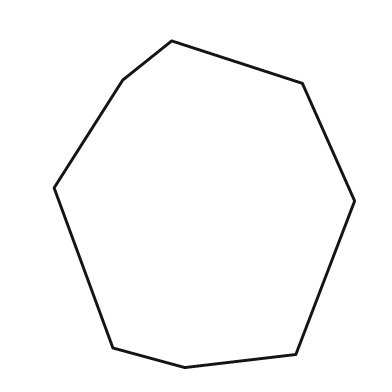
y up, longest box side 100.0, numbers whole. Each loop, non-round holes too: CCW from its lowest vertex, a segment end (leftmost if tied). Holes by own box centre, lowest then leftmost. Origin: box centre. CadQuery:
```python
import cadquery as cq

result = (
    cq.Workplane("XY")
    .moveTo(-6.0, -50.0)
    .lineTo(28.0, -46.0)
    .lineTo(46.0, 1.0)
    .lineTo(30.0, 37.0)
    .lineTo(-10.0, 50.0)
    .lineTo(-25.0, 38.0)
    .lineTo(-46.0, 5.0)
    .lineTo(-28.0, -44.0)
    .close()
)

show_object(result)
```